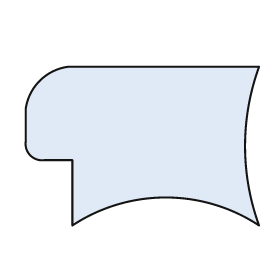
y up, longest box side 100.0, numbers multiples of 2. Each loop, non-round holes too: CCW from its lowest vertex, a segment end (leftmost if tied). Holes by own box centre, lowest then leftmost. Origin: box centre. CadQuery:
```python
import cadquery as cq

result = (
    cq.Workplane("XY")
    .moveTo(-30.0, -34.0)
    .threePointArc((10.0, -22.0), (50.0, -34.0))
    .threePointArc((44.0, 0.0), (50.0, 34.0))
    .lineTo(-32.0, 34.0)
    .threePointArc((-44.0, 28.0), (-50.0, 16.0))
    .lineTo(-50.0, 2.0)
    .threePointArc((-48.0, -4.0), (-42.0, -6.0))
    .lineTo(-30.0, -6.0)
    .close()
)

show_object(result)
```